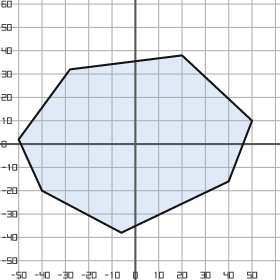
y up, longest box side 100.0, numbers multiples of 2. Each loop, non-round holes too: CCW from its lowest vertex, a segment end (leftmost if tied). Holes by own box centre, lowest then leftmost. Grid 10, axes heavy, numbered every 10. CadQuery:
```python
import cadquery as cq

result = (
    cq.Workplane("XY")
    .moveTo(-6.0, -38.0)
    .lineTo(40.0, -16.0)
    .lineTo(50.0, 10.0)
    .lineTo(20.0, 38.0)
    .lineTo(-28.0, 32.0)
    .lineTo(-50.0, 2.0)
    .lineTo(-40.0, -20.0)
    .close()
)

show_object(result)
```